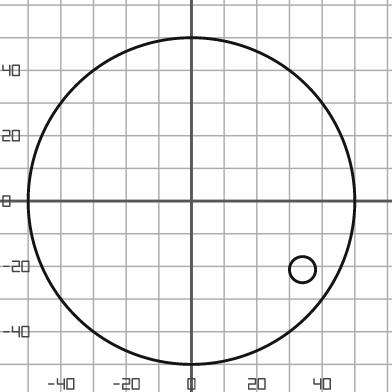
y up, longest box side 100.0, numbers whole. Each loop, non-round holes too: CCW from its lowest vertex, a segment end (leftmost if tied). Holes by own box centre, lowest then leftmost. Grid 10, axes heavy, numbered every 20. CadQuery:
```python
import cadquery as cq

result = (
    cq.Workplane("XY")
    .moveTo(0.0, 0.0)
    .circle(50.0)
    .moveTo(34.0, -21.0)
    .circle(4.0)
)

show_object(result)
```